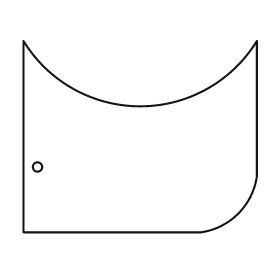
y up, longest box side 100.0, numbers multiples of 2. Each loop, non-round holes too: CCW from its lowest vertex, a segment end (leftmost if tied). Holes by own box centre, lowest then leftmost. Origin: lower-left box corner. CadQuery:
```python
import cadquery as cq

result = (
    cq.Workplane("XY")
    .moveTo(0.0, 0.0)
    .lineTo(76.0, 0.0)
    .threePointArc((92.0, 8.0), (100.0, 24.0))
    .lineTo(100.0, 82.0)
    .threePointArc((50.0, 54.0), (0.0, 82.0))
    .close()
    .moveTo(6.0, 28.0)
    .circle(2.0)
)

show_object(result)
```